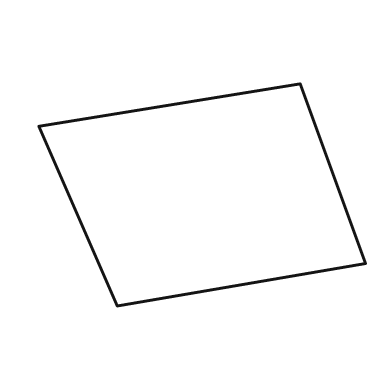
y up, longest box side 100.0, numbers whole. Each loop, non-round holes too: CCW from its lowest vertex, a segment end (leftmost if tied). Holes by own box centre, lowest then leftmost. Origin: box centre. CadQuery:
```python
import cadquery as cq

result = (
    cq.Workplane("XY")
    .moveTo(-26.0, -34.0)
    .lineTo(50.0, -21.0)
    .lineTo(30.0, 34.0)
    .lineTo(-50.0, 21.0)
    .close()
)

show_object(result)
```